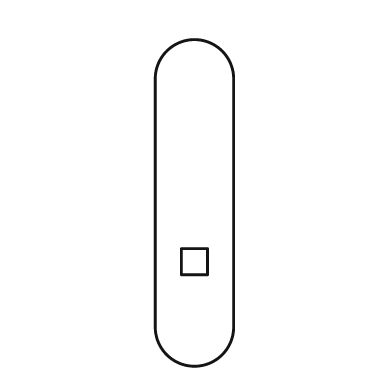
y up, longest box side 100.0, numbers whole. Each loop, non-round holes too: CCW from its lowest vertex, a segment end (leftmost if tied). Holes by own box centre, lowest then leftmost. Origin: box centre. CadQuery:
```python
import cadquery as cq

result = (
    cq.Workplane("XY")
    .moveTo(-12.0, -38.0)
    .threePointArc((0.0, -50.0), (12.0, -38.0))
    .lineTo(12.0, 38.0)
    .threePointArc((0.0, 50.0), (-12.0, 38.0))
    .close()
    .moveTo(-4.0, -22.0)
    .lineTo(4.0, -22.0)
    .lineTo(4.0, -14.0)
    .lineTo(-4.0, -14.0)
    .close()
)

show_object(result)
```